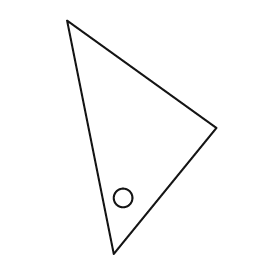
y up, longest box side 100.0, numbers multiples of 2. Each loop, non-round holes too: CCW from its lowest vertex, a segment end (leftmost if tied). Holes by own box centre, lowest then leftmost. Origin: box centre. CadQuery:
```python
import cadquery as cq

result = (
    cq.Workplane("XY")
    .moveTo(-12.0, -50.0)
    .lineTo(32.0, 4.0)
    .lineTo(-32.0, 50.0)
    .close()
    .moveTo(-8.0, -26.0)
    .circle(4.0)
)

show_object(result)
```